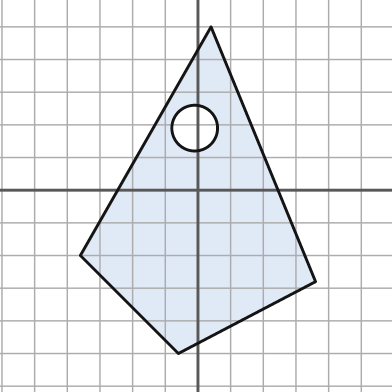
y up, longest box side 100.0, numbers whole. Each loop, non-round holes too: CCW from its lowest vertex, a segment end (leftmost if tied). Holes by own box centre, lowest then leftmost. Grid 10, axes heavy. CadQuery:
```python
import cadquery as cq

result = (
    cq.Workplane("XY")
    .moveTo(-6.0, -50.0)
    .lineTo(36.0, -28.0)
    .lineTo(4.0, 50.0)
    .lineTo(-36.0, -20.0)
    .close()
    .moveTo(-1.0, 19.0)
    .circle(7.0)
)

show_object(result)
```